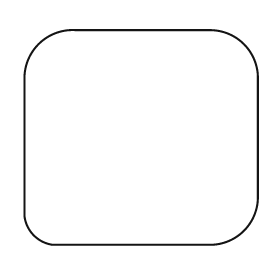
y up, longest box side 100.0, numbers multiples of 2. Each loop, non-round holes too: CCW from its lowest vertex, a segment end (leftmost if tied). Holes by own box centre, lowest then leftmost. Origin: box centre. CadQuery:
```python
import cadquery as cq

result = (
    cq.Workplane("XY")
    .moveTo(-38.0, -46.0)
    .lineTo(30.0, -46.0)
    .threePointArc((44.0, -40.0), (50.0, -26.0))
    .lineTo(50.0, 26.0)
    .threePointArc((44.0, 40.0), (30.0, 46.0))
    .lineTo(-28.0, 46.0)
    .threePointArc((-44.0, 40.0), (-50.0, 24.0))
    .lineTo(-50.0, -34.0)
    .threePointArc((-46.0, -42.0), (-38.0, -46.0))
    .close()
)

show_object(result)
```